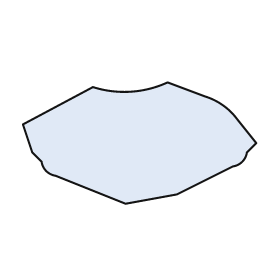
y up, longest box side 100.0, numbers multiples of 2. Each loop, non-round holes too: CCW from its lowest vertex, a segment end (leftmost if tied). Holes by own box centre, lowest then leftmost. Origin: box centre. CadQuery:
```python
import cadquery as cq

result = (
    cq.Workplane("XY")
    .moveTo(-6.0, -26.0)
    .lineTo(16.0, -22.0)
    .lineTo(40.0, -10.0)
    .threePointArc((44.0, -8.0), (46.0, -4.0))
    .lineTo(50.0, 0.0)
    .lineTo(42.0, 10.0)
    .threePointArc((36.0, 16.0), (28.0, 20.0))
    .lineTo(12.0, 26.0)
    .threePointArc((-4.0, 22.0), (-20.0, 24.0))
    .lineTo(-50.0, 8.0)
    .lineTo(-46.0, -4.0)
    .lineTo(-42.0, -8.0)
    .threePointArc((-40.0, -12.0), (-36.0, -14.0))
    .close()
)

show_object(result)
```